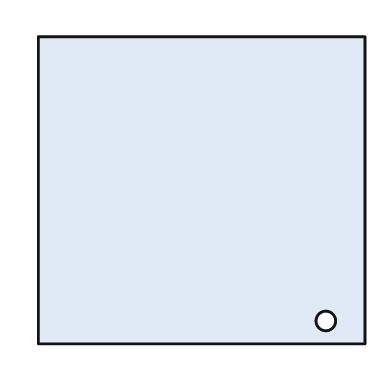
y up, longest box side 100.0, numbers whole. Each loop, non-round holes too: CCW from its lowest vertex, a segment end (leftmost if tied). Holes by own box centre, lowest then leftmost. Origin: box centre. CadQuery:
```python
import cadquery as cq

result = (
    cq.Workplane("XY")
    .moveTo(-50.0, -47.0)
    .lineTo(50.0, -47.0)
    .lineTo(50.0, 47.0)
    .lineTo(-50.0, 47.0)
    .close()
    .moveTo(38.0, -40.0)
    .circle(3.0)
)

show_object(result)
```